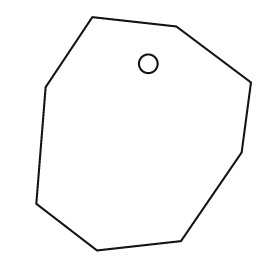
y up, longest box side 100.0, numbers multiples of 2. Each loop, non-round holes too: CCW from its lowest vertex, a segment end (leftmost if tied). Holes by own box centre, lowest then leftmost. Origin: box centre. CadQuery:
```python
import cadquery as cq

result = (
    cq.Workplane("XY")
    .moveTo(-20.0, -50.0)
    .lineTo(16.0, -46.0)
    .lineTo(42.0, -8.0)
    .lineTo(46.0, 22.0)
    .lineTo(14.0, 46.0)
    .lineTo(-22.0, 50.0)
    .lineTo(-42.0, 20.0)
    .lineTo(-46.0, -30.0)
    .close()
    .moveTo(2.0, 30.0)
    .circle(4.0)
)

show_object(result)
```